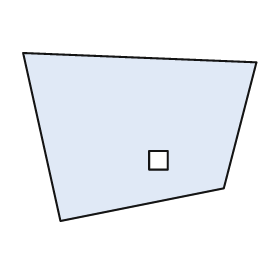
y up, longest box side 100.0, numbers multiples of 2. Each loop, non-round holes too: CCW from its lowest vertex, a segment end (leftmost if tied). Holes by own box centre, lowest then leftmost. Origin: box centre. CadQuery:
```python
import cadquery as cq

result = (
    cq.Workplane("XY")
    .moveTo(-34.0, -36.0)
    .lineTo(36.0, -22.0)
    .lineTo(50.0, 32.0)
    .lineTo(-50.0, 36.0)
    .close()
    .moveTo(4.0, -14.0)
    .lineTo(12.0, -14.0)
    .lineTo(12.0, -6.0)
    .lineTo(4.0, -6.0)
    .close()
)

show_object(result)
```